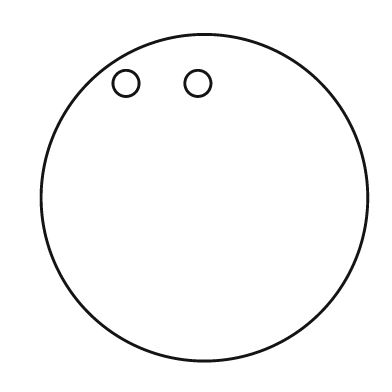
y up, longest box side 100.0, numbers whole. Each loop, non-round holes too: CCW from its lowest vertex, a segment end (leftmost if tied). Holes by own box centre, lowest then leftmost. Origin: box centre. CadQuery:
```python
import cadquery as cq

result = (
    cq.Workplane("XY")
    .moveTo(0.0, 0.0)
    .circle(50.0)
    .moveTo(-24.0, 35.0)
    .circle(4.0)
    .moveTo(-2.0, 35.0)
    .circle(4.0)
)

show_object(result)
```